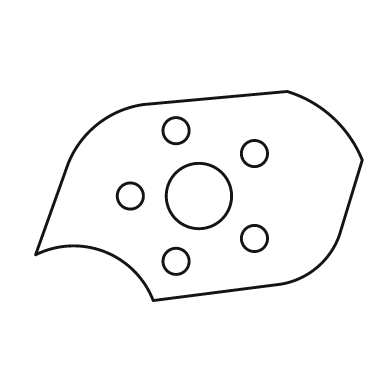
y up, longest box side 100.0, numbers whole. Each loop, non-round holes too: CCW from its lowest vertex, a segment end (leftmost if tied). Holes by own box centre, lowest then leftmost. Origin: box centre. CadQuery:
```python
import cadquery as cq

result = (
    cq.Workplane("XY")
    .moveTo(-14.0, -32.0)
    .lineTo(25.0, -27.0)
    .threePointArc((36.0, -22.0), (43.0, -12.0))
    .lineTo(50.0, 11.0)
    .threePointArc((41.0, 24.0), (27.0, 32.0))
    .lineTo(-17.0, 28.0)
    .threePointArc((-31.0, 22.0), (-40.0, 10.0))
    .lineTo(-50.0, -18.0)
    .threePointArc((-29.0, -17.0), (-14.0, -32.0))
    .close()
    .moveTo(-7.0, -20.0)
    .circle(4.0)
    .moveTo(17.0, -13.0)
    .circle(4.0)
    .moveTo(-21.0, 0.0)
    .circle(4.0)
    .moveTo(0.0, 0.0)
    .circle(10.0)
    .moveTo(17.0, 13.0)
    .circle(4.0)
    .moveTo(-7.0, 20.0)
    .circle(4.0)
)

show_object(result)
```